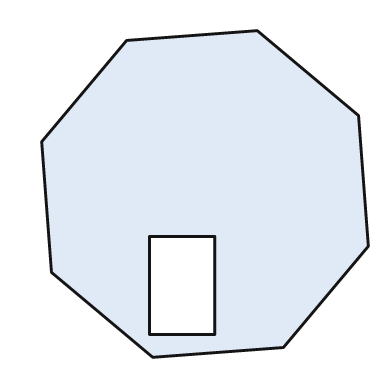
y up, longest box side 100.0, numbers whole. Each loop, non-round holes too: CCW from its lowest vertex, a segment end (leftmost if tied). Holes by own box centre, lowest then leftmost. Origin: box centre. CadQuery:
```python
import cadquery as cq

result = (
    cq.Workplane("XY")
    .moveTo(-16.0, -50.0)
    .lineTo(24.0, -47.0)
    .lineTo(50.0, -16.0)
    .lineTo(47.0, 24.0)
    .lineTo(16.0, 50.0)
    .lineTo(-24.0, 47.0)
    .lineTo(-50.0, 16.0)
    .lineTo(-47.0, -24.0)
    .close()
    .moveTo(-17.0, -43.0)
    .lineTo(3.0, -43.0)
    .lineTo(3.0, -13.0)
    .lineTo(-17.0, -13.0)
    .close()
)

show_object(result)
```